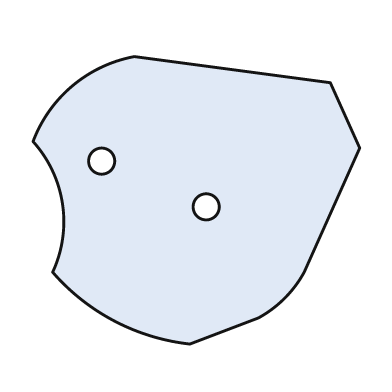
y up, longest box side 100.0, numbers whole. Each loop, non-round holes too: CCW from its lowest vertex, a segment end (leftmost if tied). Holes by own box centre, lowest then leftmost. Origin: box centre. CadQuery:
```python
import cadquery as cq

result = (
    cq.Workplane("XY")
    .moveTo(-2.0, -44.0)
    .lineTo(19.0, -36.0)
    .threePointArc((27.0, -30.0), (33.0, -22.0))
    .lineTo(50.0, 16.0)
    .lineTo(41.0, 36.0)
    .lineTo(-19.0, 44.0)
    .threePointArc((-38.0, 35.0), (-50.0, 18.0))
    .threePointArc((-41.0, -1.0), (-44.0, -22.0))
    .threePointArc((-25.0, -37.0), (-2.0, -44.0))
    .close()
    .moveTo(3.0, -2.0)
    .circle(4.0)
    .moveTo(-29.0, 12.0)
    .circle(4.0)
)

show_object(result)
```